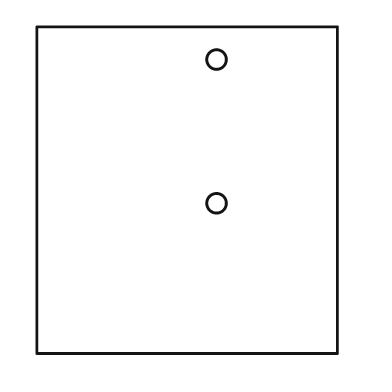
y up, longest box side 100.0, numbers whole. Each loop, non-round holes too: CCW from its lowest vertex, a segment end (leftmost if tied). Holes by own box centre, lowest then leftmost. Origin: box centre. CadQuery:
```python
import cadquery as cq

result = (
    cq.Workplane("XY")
    .moveTo(-46.0, -50.0)
    .lineTo(46.0, -50.0)
    .lineTo(46.0, 50.0)
    .lineTo(-46.0, 50.0)
    .close()
    .moveTo(9.0, -4.0)
    .circle(3.0)
    .moveTo(9.0, 40.0)
    .circle(3.0)
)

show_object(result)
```